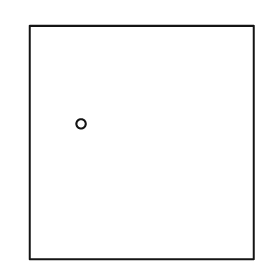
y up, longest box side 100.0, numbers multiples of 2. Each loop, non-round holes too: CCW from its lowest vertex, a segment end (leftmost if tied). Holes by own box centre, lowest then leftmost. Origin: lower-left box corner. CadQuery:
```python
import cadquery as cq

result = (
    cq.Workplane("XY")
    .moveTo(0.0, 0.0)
    .lineTo(96.0, 0.0)
    .lineTo(96.0, 100.0)
    .lineTo(0.0, 100.0)
    .close()
    .moveTo(22.0, 58.0)
    .circle(2.0)
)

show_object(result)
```